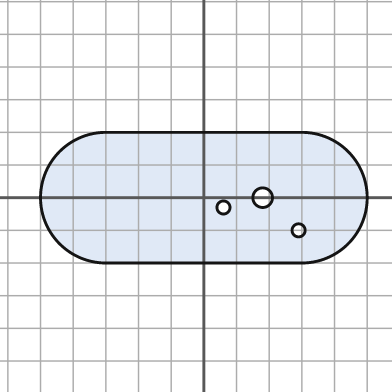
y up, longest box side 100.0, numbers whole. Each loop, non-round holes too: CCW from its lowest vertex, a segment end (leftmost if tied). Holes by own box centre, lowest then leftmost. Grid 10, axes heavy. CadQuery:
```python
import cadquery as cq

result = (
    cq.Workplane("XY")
    .moveTo(-30.0, -20.0)
    .lineTo(30.0, -20.0)
    .threePointArc((50.0, 0.0), (30.0, 20.0))
    .lineTo(-30.0, 20.0)
    .threePointArc((-50.0, 0.0), (-30.0, -20.0))
    .close()
    .moveTo(29.0, -10.0)
    .circle(2.0)
    .moveTo(6.0, -3.0)
    .circle(2.0)
    .moveTo(18.0, 0.0)
    .circle(3.0)
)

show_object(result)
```